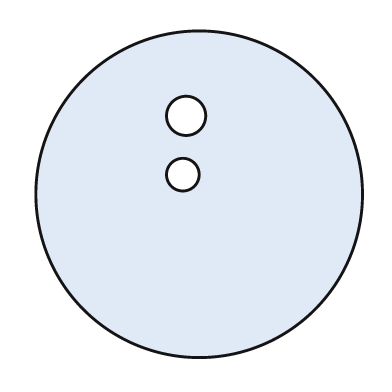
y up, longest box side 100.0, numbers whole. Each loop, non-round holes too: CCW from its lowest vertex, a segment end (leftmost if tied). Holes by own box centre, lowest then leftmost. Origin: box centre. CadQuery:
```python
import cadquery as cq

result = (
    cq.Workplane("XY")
    .moveTo(0.0, 0.0)
    .circle(50.0)
    .moveTo(-5.0, 6.0)
    .circle(5.0)
    .moveTo(-4.0, 24.0)
    .circle(6.0)
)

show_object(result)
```